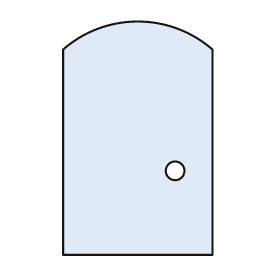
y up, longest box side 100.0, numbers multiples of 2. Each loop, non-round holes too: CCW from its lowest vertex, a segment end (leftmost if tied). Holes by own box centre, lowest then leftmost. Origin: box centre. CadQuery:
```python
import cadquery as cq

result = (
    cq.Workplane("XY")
    .moveTo(-32.0, -50.0)
    .lineTo(32.0, -50.0)
    .lineTo(32.0, 38.0)
    .threePointArc((0.0, 50.0), (-32.0, 38.0))
    .close()
    .moveTo(16.0, -14.0)
    .circle(4.0)
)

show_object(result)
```